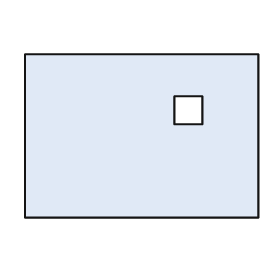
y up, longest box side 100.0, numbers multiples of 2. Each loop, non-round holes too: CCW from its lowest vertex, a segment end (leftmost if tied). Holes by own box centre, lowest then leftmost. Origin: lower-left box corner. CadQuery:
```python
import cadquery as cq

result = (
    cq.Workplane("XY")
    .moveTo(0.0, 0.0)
    .lineTo(100.0, 0.0)
    .lineTo(100.0, 70.0)
    .lineTo(0.0, 70.0)
    .close()
    .moveTo(64.0, 40.0)
    .lineTo(76.0, 40.0)
    .lineTo(76.0, 52.0)
    .lineTo(64.0, 52.0)
    .close()
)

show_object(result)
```